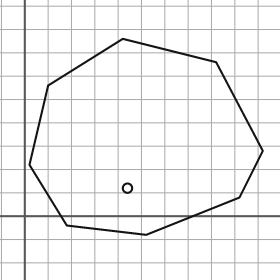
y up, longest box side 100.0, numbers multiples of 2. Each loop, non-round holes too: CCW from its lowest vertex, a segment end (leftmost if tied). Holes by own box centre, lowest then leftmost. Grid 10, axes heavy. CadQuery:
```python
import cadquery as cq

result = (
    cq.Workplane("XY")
    .moveTo(52.0, -8.0)
    .lineTo(92.0, 8.0)
    .lineTo(102.0, 28.0)
    .lineTo(82.0, 66.0)
    .lineTo(42.0, 76.0)
    .lineTo(10.0, 56.0)
    .lineTo(2.0, 22.0)
    .lineTo(18.0, -4.0)
    .close()
    .moveTo(44.0, 12.0)
    .circle(2.0)
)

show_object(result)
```